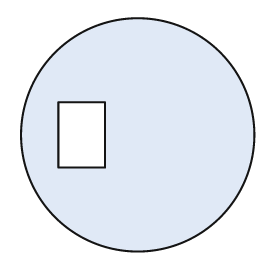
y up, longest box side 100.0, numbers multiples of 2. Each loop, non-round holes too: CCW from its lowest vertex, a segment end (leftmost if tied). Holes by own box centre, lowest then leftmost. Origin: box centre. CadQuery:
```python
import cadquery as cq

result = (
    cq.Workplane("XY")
    .moveTo(0.0, 0.0)
    .circle(50.0)
    .moveTo(-34.0, -14.0)
    .lineTo(-14.0, -14.0)
    .lineTo(-14.0, 14.0)
    .lineTo(-34.0, 14.0)
    .close()
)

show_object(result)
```